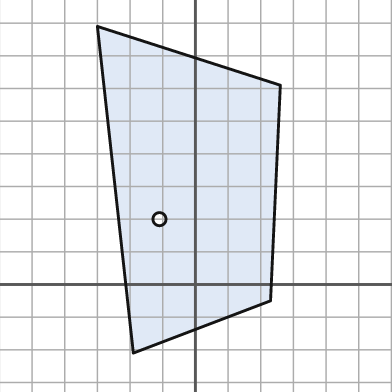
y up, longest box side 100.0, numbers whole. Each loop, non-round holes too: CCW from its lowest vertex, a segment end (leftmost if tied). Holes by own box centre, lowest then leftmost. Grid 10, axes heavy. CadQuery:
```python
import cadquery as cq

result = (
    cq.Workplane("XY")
    .moveTo(-19.0, -21.0)
    .lineTo(23.0, -5.0)
    .lineTo(26.0, 61.0)
    .lineTo(-30.0, 79.0)
    .close()
    .moveTo(-11.0, 20.0)
    .circle(2.0)
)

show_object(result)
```